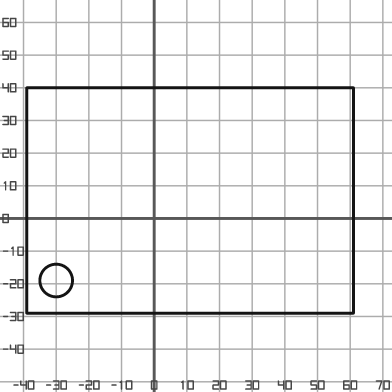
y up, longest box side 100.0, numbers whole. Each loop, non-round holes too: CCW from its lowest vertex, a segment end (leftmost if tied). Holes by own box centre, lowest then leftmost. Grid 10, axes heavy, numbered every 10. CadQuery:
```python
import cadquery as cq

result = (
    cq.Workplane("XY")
    .moveTo(-39.0, -29.0)
    .lineTo(61.0, -29.0)
    .lineTo(61.0, 40.0)
    .lineTo(-39.0, 40.0)
    .close()
    .moveTo(-30.0, -19.0)
    .circle(5.0)
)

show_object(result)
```